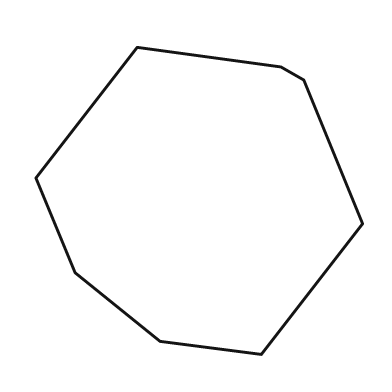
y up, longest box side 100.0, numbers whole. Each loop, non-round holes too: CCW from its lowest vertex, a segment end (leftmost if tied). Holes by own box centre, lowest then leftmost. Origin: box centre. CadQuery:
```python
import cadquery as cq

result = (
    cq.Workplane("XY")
    .moveTo(19.0, -47.0)
    .lineTo(50.0, -7.0)
    .lineTo(32.0, 37.0)
    .lineTo(25.0, 41.0)
    .lineTo(-19.0, 47.0)
    .lineTo(-50.0, 7.0)
    .lineTo(-38.0, -22.0)
    .lineTo(-12.0, -43.0)
    .close()
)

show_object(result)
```